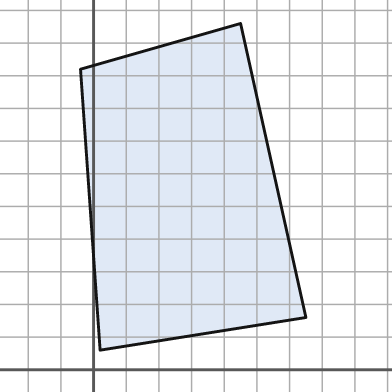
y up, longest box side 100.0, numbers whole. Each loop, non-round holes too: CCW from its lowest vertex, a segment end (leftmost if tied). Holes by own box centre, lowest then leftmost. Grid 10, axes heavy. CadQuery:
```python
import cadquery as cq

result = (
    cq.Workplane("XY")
    .moveTo(2.0, 6.0)
    .lineTo(65.0, 16.0)
    .lineTo(45.0, 106.0)
    .lineTo(-4.0, 92.0)
    .close()
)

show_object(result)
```